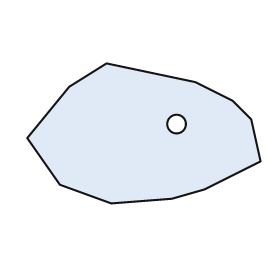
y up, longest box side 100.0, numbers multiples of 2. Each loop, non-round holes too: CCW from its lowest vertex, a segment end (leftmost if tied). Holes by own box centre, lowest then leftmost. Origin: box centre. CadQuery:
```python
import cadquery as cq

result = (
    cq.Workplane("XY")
    .moveTo(-14.0, -30.0)
    .lineTo(12.0, -28.0)
    .lineTo(26.0, -24.0)
    .lineTo(50.0, -12.0)
    .lineTo(46.0, 6.0)
    .lineTo(38.0, 14.0)
    .lineTo(22.0, 22.0)
    .lineTo(-16.0, 30.0)
    .lineTo(-32.0, 20.0)
    .lineTo(-50.0, -2.0)
    .lineTo(-36.0, -22.0)
    .close()
    .moveTo(14.0, 4.0)
    .circle(4.0)
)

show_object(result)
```